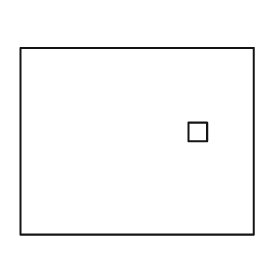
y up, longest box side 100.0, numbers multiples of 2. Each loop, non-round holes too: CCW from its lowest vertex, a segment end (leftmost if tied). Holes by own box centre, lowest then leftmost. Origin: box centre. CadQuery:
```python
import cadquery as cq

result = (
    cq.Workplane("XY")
    .moveTo(-50.0, -40.0)
    .lineTo(50.0, -40.0)
    .lineTo(50.0, 40.0)
    .lineTo(-50.0, 40.0)
    .close()
    .moveTo(22.0, 0.0)
    .lineTo(30.0, 0.0)
    .lineTo(30.0, 8.0)
    .lineTo(22.0, 8.0)
    .close()
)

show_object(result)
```